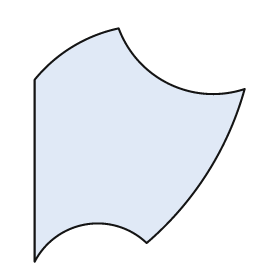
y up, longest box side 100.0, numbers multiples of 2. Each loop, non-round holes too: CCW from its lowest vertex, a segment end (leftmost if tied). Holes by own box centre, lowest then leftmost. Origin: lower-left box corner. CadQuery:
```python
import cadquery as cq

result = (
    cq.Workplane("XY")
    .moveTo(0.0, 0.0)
    .threePointArc((22.0, 16.0), (48.0, 8.0))
    .threePointArc((74.0, 38.0), (90.0, 74.0))
    .threePointArc((58.0, 76.0), (36.0, 100.0))
    .threePointArc((16.0, 92.0), (0.0, 78.0))
    .close()
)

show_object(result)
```